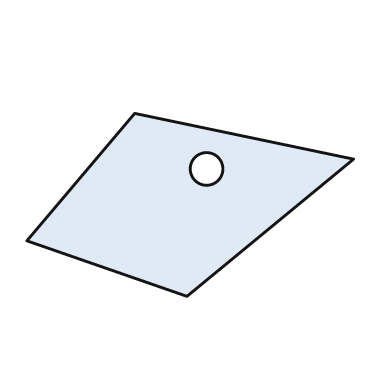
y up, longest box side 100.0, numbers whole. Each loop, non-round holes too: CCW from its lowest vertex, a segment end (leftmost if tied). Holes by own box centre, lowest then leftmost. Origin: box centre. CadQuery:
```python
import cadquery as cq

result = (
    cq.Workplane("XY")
    .moveTo(-1.0, -28.0)
    .lineTo(50.0, 14.0)
    .lineTo(-17.0, 28.0)
    .lineTo(-50.0, -11.0)
    .close()
    .moveTo(5.0, 11.0)
    .circle(5.0)
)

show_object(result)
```